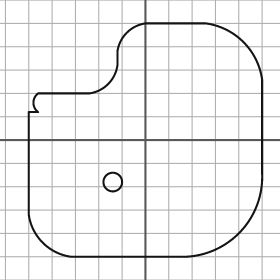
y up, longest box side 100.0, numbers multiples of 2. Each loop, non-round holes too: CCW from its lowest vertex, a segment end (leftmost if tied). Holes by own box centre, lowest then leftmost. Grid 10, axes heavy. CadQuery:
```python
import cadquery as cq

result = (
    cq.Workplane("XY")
    .moveTo(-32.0, -50.0)
    .lineTo(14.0, -50.0)
    .threePointArc((40.0, -40.0), (50.0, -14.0))
    .lineTo(50.0, 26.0)
    .threePointArc((42.0, 42.0), (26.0, 50.0))
    .lineTo(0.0, 50.0)
    .threePointArc((-8.0, 46.0), (-12.0, 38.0))
    .lineTo(-12.0, 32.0)
    .threePointArc((-16.0, 24.0), (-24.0, 20.0))
    .lineTo(-46.0, 20.0)
    .threePointArc((-48.0, 16.0), (-46.0, 12.0))
    .lineTo(-50.0, 12.0)
    .lineTo(-50.0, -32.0)
    .threePointArc((-44.0, -44.0), (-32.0, -50.0))
    .close()
    .moveTo(-14.0, -18.0)
    .circle(4.0)
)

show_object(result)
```